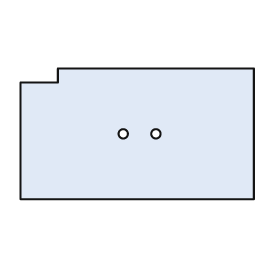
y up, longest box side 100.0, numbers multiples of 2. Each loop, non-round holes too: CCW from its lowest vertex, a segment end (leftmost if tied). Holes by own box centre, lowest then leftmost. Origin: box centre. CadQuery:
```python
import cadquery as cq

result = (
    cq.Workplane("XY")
    .moveTo(-50.0, -28.0)
    .lineTo(50.0, -28.0)
    .lineTo(50.0, 28.0)
    .lineTo(-34.0, 28.0)
    .lineTo(-34.0, 22.0)
    .lineTo(-50.0, 22.0)
    .close()
    .moveTo(-6.0, 0.0)
    .circle(2.0)
    .moveTo(8.0, 0.0)
    .circle(2.0)
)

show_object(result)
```